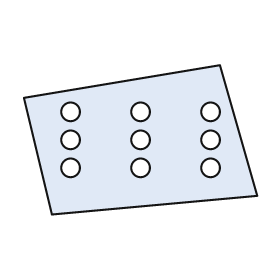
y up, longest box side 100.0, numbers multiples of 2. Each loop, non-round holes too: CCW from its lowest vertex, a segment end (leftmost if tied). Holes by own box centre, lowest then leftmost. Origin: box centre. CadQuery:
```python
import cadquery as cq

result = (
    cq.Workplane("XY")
    .moveTo(-38.0, -32.0)
    .lineTo(50.0, -24.0)
    .lineTo(34.0, 32.0)
    .lineTo(-50.0, 18.0)
    .close()
    .moveTo(-30.0, -12.0)
    .circle(4.0)
    .moveTo(0.0, -12.0)
    .circle(4.0)
    .moveTo(30.0, -12.0)
    .circle(4.0)
    .moveTo(-30.0, 0.0)
    .circle(4.0)
    .moveTo(0.0, 0.0)
    .circle(4.0)
    .moveTo(30.0, 0.0)
    .circle(4.0)
    .moveTo(-30.0, 12.0)
    .circle(4.0)
    .moveTo(0.0, 12.0)
    .circle(4.0)
    .moveTo(30.0, 12.0)
    .circle(4.0)
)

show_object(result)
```